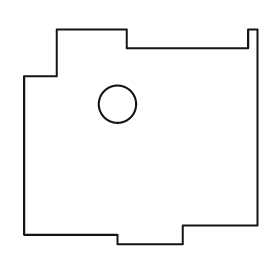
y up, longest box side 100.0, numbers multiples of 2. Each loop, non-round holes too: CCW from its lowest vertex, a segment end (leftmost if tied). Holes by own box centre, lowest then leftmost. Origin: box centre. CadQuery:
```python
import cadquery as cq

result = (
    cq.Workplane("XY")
    .moveTo(-10.0, -46.0)
    .lineTo(18.0, -46.0)
    .lineTo(18.0, -38.0)
    .lineTo(50.0, -38.0)
    .lineTo(50.0, 46.0)
    .lineTo(46.0, 46.0)
    .lineTo(46.0, 38.0)
    .lineTo(-6.0, 38.0)
    .lineTo(-6.0, 46.0)
    .lineTo(-36.0, 46.0)
    .lineTo(-36.0, 26.0)
    .lineTo(-50.0, 26.0)
    .lineTo(-50.0, -42.0)
    .lineTo(-10.0, -42.0)
    .close()
    .moveTo(-10.0, 14.0)
    .circle(8.0)
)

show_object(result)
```